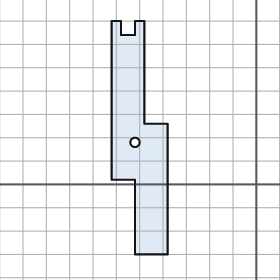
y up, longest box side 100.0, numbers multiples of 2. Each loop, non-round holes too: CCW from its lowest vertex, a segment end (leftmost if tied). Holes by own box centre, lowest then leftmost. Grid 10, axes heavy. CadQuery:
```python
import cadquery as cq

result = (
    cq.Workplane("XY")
    .moveTo(-52.0, -30.0)
    .lineTo(-38.0, -30.0)
    .lineTo(-38.0, 26.0)
    .lineTo(-48.0, 26.0)
    .lineTo(-48.0, 70.0)
    .lineTo(-52.0, 70.0)
    .lineTo(-52.0, 64.0)
    .lineTo(-58.0, 64.0)
    .lineTo(-58.0, 70.0)
    .lineTo(-62.0, 70.0)
    .lineTo(-62.0, 2.0)
    .lineTo(-52.0, 2.0)
    .close()
    .moveTo(-52.0, 18.0)
    .circle(2.0)
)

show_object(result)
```